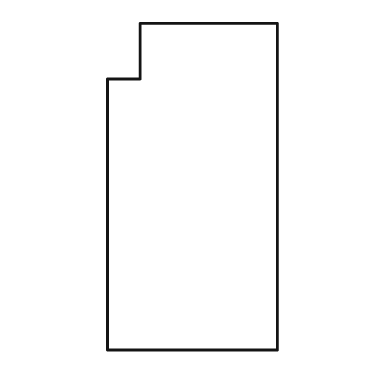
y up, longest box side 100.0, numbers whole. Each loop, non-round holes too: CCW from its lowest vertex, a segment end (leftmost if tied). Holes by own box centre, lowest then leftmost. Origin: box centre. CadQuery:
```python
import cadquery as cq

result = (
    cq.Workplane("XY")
    .moveTo(-26.0, -50.0)
    .lineTo(26.0, -50.0)
    .lineTo(26.0, 50.0)
    .lineTo(-16.0, 50.0)
    .lineTo(-16.0, 33.0)
    .lineTo(-26.0, 33.0)
    .close()
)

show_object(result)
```